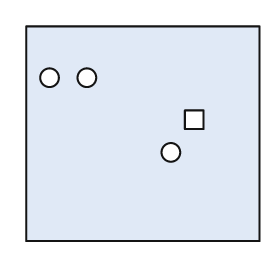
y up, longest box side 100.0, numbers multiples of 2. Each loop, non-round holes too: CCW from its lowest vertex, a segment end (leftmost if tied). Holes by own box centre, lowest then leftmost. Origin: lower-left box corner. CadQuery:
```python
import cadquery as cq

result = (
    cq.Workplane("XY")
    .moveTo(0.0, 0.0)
    .lineTo(100.0, 0.0)
    .lineTo(100.0, 92.0)
    .lineTo(0.0, 92.0)
    .close()
    .moveTo(62.0, 38.0)
    .circle(4.0)
    .moveTo(68.0, 48.0)
    .lineTo(76.0, 48.0)
    .lineTo(76.0, 56.0)
    .lineTo(68.0, 56.0)
    .close()
    .moveTo(10.0, 70.0)
    .circle(4.0)
    .moveTo(26.0, 70.0)
    .circle(4.0)
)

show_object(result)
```